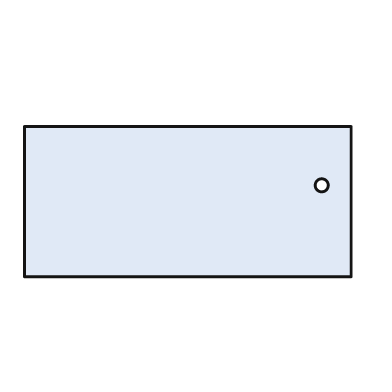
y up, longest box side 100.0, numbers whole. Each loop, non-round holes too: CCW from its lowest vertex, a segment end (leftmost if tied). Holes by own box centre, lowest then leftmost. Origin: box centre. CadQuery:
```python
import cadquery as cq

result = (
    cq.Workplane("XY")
    .moveTo(-50.0, -23.0)
    .lineTo(50.0, -23.0)
    .lineTo(50.0, 23.0)
    .lineTo(-50.0, 23.0)
    .close()
    .moveTo(41.0, 5.0)
    .circle(2.0)
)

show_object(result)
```